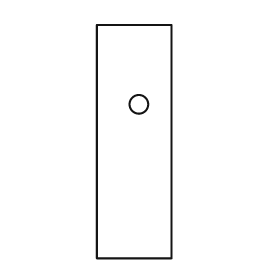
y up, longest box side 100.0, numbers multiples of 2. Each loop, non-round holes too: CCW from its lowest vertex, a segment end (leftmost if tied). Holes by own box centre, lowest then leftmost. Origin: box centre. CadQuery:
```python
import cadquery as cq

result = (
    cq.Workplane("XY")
    .moveTo(-16.0, -50.0)
    .lineTo(16.0, -50.0)
    .lineTo(16.0, 50.0)
    .lineTo(-16.0, 50.0)
    .close()
    .moveTo(2.0, 16.0)
    .circle(4.0)
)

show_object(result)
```